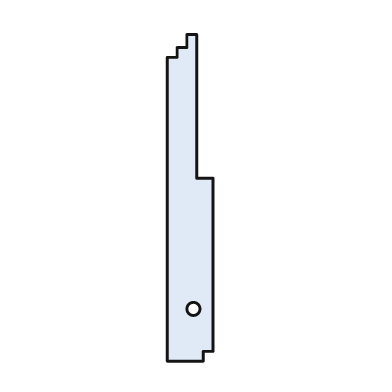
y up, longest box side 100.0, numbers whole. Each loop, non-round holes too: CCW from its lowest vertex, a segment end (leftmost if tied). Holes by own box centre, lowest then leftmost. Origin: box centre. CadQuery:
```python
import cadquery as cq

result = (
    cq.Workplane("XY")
    .moveTo(-7.0, -50.0)
    .lineTo(4.0, -50.0)
    .lineTo(4.0, -47.0)
    .lineTo(7.0, -47.0)
    .lineTo(7.0, 6.0)
    .lineTo(2.0, 6.0)
    .lineTo(2.0, 50.0)
    .lineTo(-1.0, 50.0)
    .lineTo(-1.0, 46.0)
    .lineTo(-4.0, 46.0)
    .lineTo(-4.0, 43.0)
    .lineTo(-7.0, 43.0)
    .close()
    .moveTo(1.0, -34.0)
    .circle(2.0)
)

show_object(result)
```